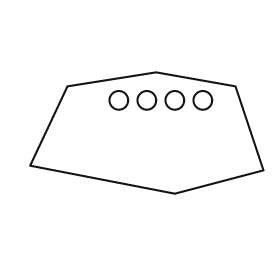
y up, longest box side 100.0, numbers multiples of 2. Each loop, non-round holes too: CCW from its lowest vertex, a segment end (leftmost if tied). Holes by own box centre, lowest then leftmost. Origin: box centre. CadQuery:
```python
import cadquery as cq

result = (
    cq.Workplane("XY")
    .moveTo(12.0, -26.0)
    .lineTo(50.0, -16.0)
    .lineTo(38.0, 20.0)
    .lineTo(4.0, 26.0)
    .lineTo(-34.0, 20.0)
    .lineTo(-50.0, -14.0)
    .close()
    .moveTo(-12.0, 14.0)
    .circle(4.0)
    .moveTo(0.0, 14.0)
    .circle(4.0)
    .moveTo(12.0, 14.0)
    .circle(4.0)
    .moveTo(24.0, 14.0)
    .circle(4.0)
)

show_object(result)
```